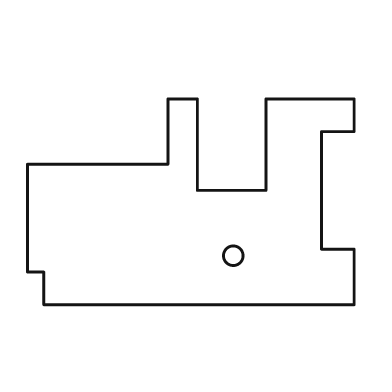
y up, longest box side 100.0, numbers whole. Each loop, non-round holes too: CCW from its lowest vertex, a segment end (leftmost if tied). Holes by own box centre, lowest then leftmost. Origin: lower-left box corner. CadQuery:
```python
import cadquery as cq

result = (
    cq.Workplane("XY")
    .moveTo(5.0, 0.0)
    .lineTo(100.0, 0.0)
    .lineTo(100.0, 17.0)
    .lineTo(90.0, 17.0)
    .lineTo(90.0, 53.0)
    .lineTo(100.0, 53.0)
    .lineTo(100.0, 63.0)
    .lineTo(73.0, 63.0)
    .lineTo(73.0, 35.0)
    .lineTo(52.0, 35.0)
    .lineTo(52.0, 63.0)
    .lineTo(43.0, 63.0)
    .lineTo(43.0, 43.0)
    .lineTo(0.0, 43.0)
    .lineTo(0.0, 10.0)
    .lineTo(5.0, 10.0)
    .close()
    .moveTo(63.0, 15.0)
    .circle(3.0)
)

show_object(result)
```